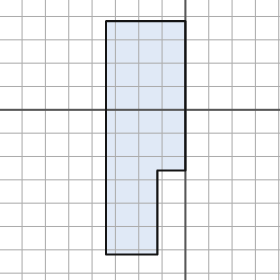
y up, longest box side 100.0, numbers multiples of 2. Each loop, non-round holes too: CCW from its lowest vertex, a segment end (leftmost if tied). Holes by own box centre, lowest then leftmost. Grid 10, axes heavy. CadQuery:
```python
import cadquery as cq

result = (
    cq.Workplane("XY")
    .moveTo(-34.0, -62.0)
    .lineTo(-12.0, -62.0)
    .lineTo(-12.0, -26.0)
    .lineTo(0.0, -26.0)
    .lineTo(0.0, 38.0)
    .lineTo(-34.0, 38.0)
    .close()
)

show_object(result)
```